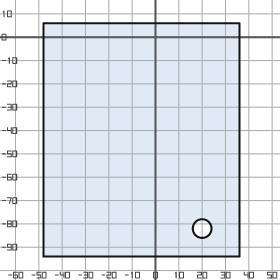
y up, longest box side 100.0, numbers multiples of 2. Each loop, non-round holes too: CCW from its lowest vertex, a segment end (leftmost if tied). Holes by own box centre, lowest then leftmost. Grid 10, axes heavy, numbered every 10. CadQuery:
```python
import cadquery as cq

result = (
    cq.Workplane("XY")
    .moveTo(-48.0, -94.0)
    .lineTo(36.0, -94.0)
    .lineTo(36.0, 6.0)
    .lineTo(-48.0, 6.0)
    .close()
    .moveTo(20.0, -82.0)
    .circle(4.0)
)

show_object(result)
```